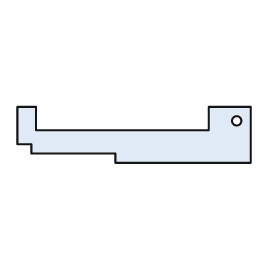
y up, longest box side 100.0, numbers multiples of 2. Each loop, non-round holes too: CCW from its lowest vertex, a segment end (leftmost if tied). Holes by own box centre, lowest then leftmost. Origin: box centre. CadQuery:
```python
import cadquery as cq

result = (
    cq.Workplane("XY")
    .moveTo(-8.0, -12.0)
    .lineTo(50.0, -12.0)
    .lineTo(50.0, 12.0)
    .lineTo(32.0, 12.0)
    .lineTo(32.0, 2.0)
    .lineTo(-42.0, 2.0)
    .lineTo(-42.0, 12.0)
    .lineTo(-50.0, 12.0)
    .lineTo(-50.0, -4.0)
    .lineTo(-44.0, -4.0)
    .lineTo(-44.0, -8.0)
    .lineTo(-8.0, -8.0)
    .close()
    .moveTo(44.0, 6.0)
    .circle(2.0)
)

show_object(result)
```